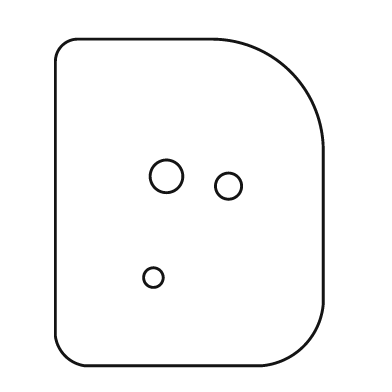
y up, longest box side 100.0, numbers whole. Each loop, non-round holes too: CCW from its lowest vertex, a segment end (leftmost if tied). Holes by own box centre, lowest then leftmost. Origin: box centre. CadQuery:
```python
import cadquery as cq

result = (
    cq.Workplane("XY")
    .moveTo(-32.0, -50.0)
    .lineTo(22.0, -50.0)
    .threePointArc((35.0, -44.0), (41.0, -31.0))
    .lineTo(41.0, 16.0)
    .threePointArc((31.0, 40.0), (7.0, 50.0))
    .lineTo(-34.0, 50.0)
    .threePointArc((-39.0, 48.0), (-41.0, 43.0))
    .lineTo(-41.0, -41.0)
    .threePointArc((-38.0, -47.0), (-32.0, -50.0))
    .close()
    .moveTo(-11.0, -23.0)
    .circle(3.0)
    .moveTo(12.0, 5.0)
    .circle(4.0)
    .moveTo(-7.0, 8.0)
    .circle(5.0)
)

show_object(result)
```